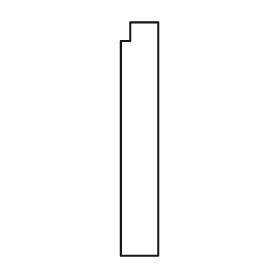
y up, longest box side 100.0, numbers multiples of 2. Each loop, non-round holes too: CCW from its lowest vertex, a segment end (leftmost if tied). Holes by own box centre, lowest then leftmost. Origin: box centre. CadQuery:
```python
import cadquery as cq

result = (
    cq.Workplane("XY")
    .moveTo(-8.0, -50.0)
    .lineTo(8.0, -50.0)
    .lineTo(8.0, 50.0)
    .lineTo(-4.0, 50.0)
    .lineTo(-4.0, 42.0)
    .lineTo(-8.0, 42.0)
    .close()
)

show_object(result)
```